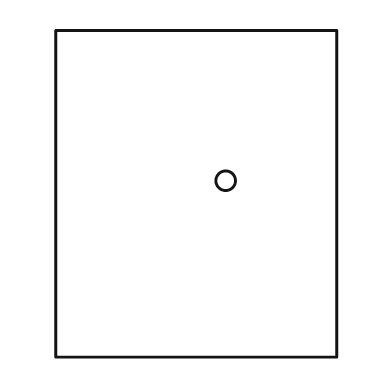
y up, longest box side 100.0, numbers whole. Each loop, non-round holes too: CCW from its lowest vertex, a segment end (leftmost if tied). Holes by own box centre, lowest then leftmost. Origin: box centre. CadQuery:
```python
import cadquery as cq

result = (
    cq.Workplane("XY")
    .moveTo(-43.0, -50.0)
    .lineTo(43.0, -50.0)
    .lineTo(43.0, 50.0)
    .lineTo(-43.0, 50.0)
    .close()
    .moveTo(9.0, 4.0)
    .circle(3.0)
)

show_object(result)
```